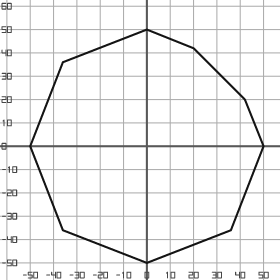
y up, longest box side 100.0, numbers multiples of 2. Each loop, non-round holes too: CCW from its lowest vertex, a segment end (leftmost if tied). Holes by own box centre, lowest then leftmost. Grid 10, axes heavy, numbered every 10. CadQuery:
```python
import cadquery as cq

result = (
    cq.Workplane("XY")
    .moveTo(0.0, -50.0)
    .lineTo(36.0, -36.0)
    .lineTo(50.0, 0.0)
    .lineTo(42.0, 20.0)
    .lineTo(20.0, 42.0)
    .lineTo(0.0, 50.0)
    .lineTo(-36.0, 36.0)
    .lineTo(-50.0, 0.0)
    .lineTo(-36.0, -36.0)
    .close()
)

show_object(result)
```